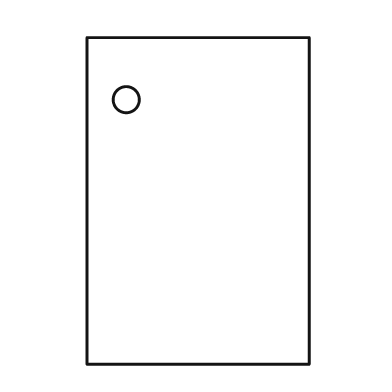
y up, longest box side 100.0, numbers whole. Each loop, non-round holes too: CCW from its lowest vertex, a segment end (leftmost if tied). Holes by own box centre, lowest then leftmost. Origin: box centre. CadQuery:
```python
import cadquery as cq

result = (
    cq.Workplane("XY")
    .moveTo(-34.0, -50.0)
    .lineTo(34.0, -50.0)
    .lineTo(34.0, 50.0)
    .lineTo(-34.0, 50.0)
    .close()
    .moveTo(-22.0, 31.0)
    .circle(4.0)
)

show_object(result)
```